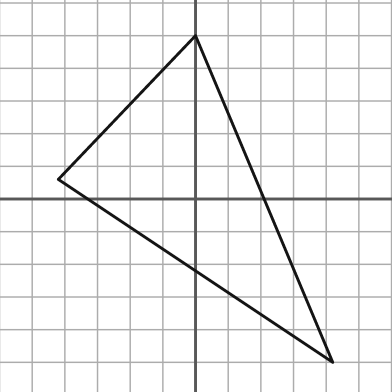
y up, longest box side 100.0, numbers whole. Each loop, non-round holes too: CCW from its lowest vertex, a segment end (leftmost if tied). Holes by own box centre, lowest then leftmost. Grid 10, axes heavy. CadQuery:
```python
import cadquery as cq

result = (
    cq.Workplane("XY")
    .moveTo(42.0, -50.0)
    .lineTo(0.0, 50.0)
    .lineTo(-42.0, 6.0)
    .close()
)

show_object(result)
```